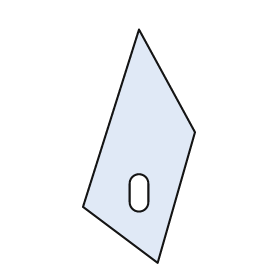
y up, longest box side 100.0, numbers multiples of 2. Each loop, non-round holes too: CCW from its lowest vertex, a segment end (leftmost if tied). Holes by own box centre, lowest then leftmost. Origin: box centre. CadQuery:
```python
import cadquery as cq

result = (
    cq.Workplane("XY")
    .moveTo(8.0, -50.0)
    .lineTo(24.0, 6.0)
    .lineTo(0.0, 50.0)
    .lineTo(-24.0, -26.0)
    .close()
    .moveTo(-4.0, -24.0)
    .threePointArc((0.0, -28.0), (4.0, -24.0))
    .lineTo(4.0, -16.0)
    .threePointArc((0.0, -12.0), (-4.0, -16.0))
    .close()
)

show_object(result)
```